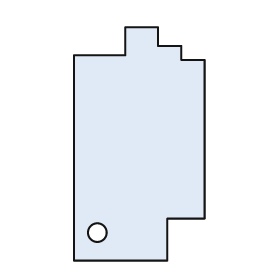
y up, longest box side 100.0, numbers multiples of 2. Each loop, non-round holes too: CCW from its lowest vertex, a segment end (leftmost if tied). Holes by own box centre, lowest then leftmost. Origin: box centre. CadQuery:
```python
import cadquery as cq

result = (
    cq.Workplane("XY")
    .moveTo(-28.0, -50.0)
    .lineTo(12.0, -50.0)
    .lineTo(12.0, -32.0)
    .lineTo(28.0, -32.0)
    .lineTo(28.0, 36.0)
    .lineTo(18.0, 36.0)
    .lineTo(18.0, 42.0)
    .lineTo(8.0, 42.0)
    .lineTo(8.0, 50.0)
    .lineTo(-6.0, 50.0)
    .lineTo(-6.0, 38.0)
    .lineTo(-28.0, 38.0)
    .close()
    .moveTo(-18.0, -38.0)
    .circle(4.0)
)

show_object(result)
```